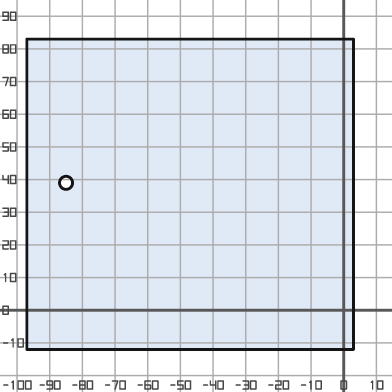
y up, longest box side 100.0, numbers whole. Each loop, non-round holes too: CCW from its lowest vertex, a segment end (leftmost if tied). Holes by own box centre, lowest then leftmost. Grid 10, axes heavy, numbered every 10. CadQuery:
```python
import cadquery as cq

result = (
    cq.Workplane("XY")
    .moveTo(-97.0, -12.0)
    .lineTo(3.0, -12.0)
    .lineTo(3.0, 83.0)
    .lineTo(-97.0, 83.0)
    .close()
    .moveTo(-85.0, 39.0)
    .circle(2.0)
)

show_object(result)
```